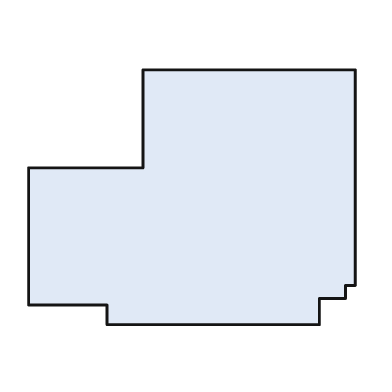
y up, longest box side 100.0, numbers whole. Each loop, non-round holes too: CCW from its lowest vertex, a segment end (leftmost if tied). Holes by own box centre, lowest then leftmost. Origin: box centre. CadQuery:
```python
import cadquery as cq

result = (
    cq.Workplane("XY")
    .moveTo(-26.0, -39.0)
    .lineTo(39.0, -39.0)
    .lineTo(39.0, -31.0)
    .lineTo(47.0, -31.0)
    .lineTo(47.0, -27.0)
    .lineTo(50.0, -27.0)
    .lineTo(50.0, 39.0)
    .lineTo(-15.0, 39.0)
    .lineTo(-15.0, 9.0)
    .lineTo(-50.0, 9.0)
    .lineTo(-50.0, -33.0)
    .lineTo(-26.0, -33.0)
    .close()
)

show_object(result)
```